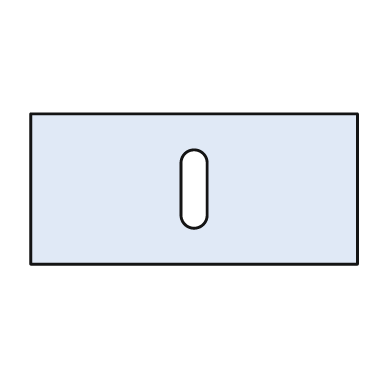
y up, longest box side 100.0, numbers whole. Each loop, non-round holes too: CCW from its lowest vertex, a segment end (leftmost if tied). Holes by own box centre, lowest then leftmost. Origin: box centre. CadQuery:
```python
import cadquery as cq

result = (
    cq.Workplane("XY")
    .moveTo(-50.0, -23.0)
    .lineTo(50.0, -23.0)
    .lineTo(50.0, 23.0)
    .lineTo(-50.0, 23.0)
    .close()
    .moveTo(-4.0, -8.0)
    .threePointArc((0.0, -12.0), (4.0, -8.0))
    .lineTo(4.0, 8.0)
    .threePointArc((0.0, 12.0), (-4.0, 8.0))
    .close()
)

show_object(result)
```